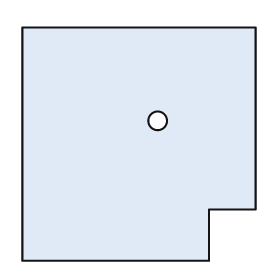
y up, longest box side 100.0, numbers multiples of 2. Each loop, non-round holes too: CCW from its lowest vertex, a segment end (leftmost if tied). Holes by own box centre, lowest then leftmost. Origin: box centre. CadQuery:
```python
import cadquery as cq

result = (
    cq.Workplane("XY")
    .moveTo(-50.0, -50.0)
    .lineTo(30.0, -50.0)
    .lineTo(30.0, -28.0)
    .lineTo(50.0, -28.0)
    .lineTo(50.0, 50.0)
    .lineTo(-50.0, 50.0)
    .close()
    .moveTo(8.0, 10.0)
    .circle(4.0)
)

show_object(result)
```